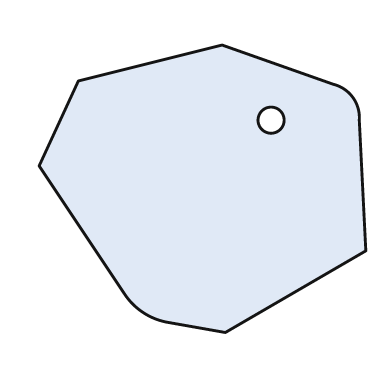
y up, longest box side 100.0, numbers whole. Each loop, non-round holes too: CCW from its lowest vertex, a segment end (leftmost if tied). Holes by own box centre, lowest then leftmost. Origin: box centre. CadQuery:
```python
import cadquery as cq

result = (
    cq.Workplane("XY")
    .moveTo(7.0, -44.0)
    .lineTo(50.0, -19.0)
    .lineTo(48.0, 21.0)
    .threePointArc((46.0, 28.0), (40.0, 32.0))
    .lineTo(6.0, 44.0)
    .lineTo(-38.0, 33.0)
    .lineTo(-50.0, 7.0)
    .lineTo(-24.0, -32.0)
    .threePointArc((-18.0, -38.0), (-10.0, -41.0))
    .close()
    .moveTo(21.0, 21.0)
    .circle(4.0)
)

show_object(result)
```